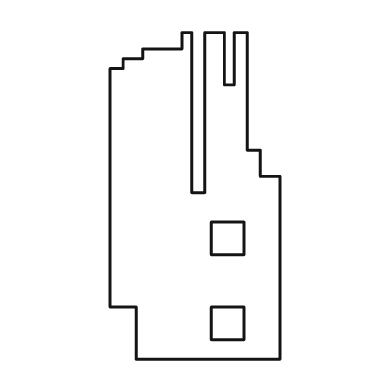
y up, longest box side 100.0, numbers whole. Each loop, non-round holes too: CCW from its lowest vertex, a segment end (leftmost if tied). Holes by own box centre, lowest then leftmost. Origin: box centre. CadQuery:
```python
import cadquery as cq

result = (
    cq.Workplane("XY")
    .moveTo(-18.0, -50.0)
    .lineTo(26.0, -50.0)
    .lineTo(26.0, 6.0)
    .lineTo(20.0, 6.0)
    .lineTo(20.0, 14.0)
    .lineTo(16.0, 14.0)
    .lineTo(16.0, 50.0)
    .lineTo(12.0, 50.0)
    .lineTo(12.0, 34.0)
    .lineTo(9.0, 34.0)
    .lineTo(9.0, 50.0)
    .lineTo(3.0, 50.0)
    .lineTo(3.0, 1.0)
    .lineTo(-1.0, 1.0)
    .lineTo(-1.0, 50.0)
    .lineTo(-4.0, 50.0)
    .lineTo(-4.0, 45.0)
    .lineTo(-16.0, 45.0)
    .lineTo(-16.0, 42.0)
    .lineTo(-22.0, 42.0)
    .lineTo(-22.0, 39.0)
    .lineTo(-26.0, 39.0)
    .lineTo(-26.0, -34.0)
    .lineTo(-18.0, -34.0)
    .close()
    .moveTo(5.0, -44.0)
    .lineTo(15.0, -44.0)
    .lineTo(15.0, -34.0)
    .lineTo(5.0, -34.0)
    .close()
    .moveTo(5.0, -18.0)
    .lineTo(15.0, -18.0)
    .lineTo(15.0, -8.0)
    .lineTo(5.0, -8.0)
    .close()
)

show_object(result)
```